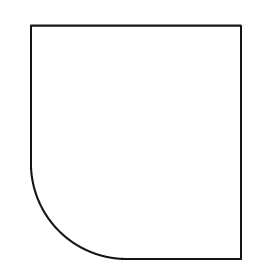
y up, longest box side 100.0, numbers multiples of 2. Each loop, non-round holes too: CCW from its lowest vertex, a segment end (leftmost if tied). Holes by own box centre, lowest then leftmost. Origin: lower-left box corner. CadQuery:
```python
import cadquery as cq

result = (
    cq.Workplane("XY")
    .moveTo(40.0, 0.0)
    .lineTo(90.0, 0.0)
    .lineTo(90.0, 100.0)
    .lineTo(0.0, 100.0)
    .lineTo(0.0, 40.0)
    .threePointArc((12.0, 12.0), (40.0, 0.0))
    .close()
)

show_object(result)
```